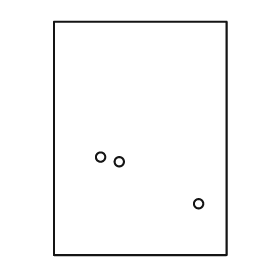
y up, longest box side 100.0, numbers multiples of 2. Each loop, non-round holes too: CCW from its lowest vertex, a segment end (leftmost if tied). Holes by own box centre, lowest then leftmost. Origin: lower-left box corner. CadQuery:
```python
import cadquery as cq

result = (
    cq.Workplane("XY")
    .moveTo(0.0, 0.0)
    .lineTo(74.0, 0.0)
    .lineTo(74.0, 100.0)
    .lineTo(0.0, 100.0)
    .close()
    .moveTo(62.0, 22.0)
    .circle(2.0)
    .moveTo(28.0, 40.0)
    .circle(2.0)
    .moveTo(20.0, 42.0)
    .circle(2.0)
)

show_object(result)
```